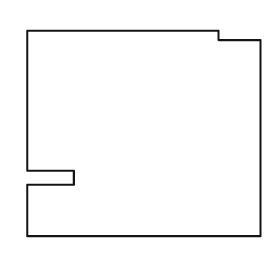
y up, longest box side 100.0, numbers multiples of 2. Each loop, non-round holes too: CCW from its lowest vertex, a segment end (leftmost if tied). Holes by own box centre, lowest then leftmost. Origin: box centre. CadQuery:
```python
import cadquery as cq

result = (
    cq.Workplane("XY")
    .moveTo(-50.0, -44.0)
    .lineTo(50.0, -44.0)
    .lineTo(50.0, 40.0)
    .lineTo(32.0, 40.0)
    .lineTo(32.0, 44.0)
    .lineTo(-50.0, 44.0)
    .lineTo(-50.0, -16.0)
    .lineTo(-30.0, -16.0)
    .lineTo(-30.0, -22.0)
    .lineTo(-50.0, -22.0)
    .close()
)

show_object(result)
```